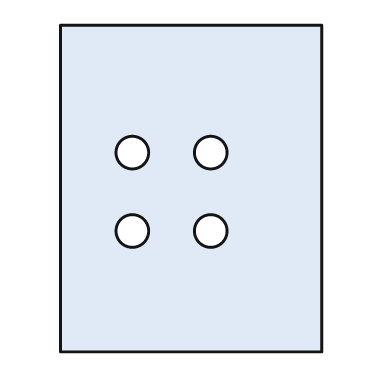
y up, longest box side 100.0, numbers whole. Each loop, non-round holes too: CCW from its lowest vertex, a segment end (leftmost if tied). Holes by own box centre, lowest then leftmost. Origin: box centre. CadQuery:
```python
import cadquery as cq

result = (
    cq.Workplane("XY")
    .moveTo(-40.0, -50.0)
    .lineTo(40.0, -50.0)
    .lineTo(40.0, 50.0)
    .lineTo(-40.0, 50.0)
    .close()
    .moveTo(-18.0, -13.0)
    .circle(5.0)
    .moveTo(6.0, -13.0)
    .circle(5.0)
    .moveTo(-18.0, 11.0)
    .circle(5.0)
    .moveTo(6.0, 11.0)
    .circle(5.0)
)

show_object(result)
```